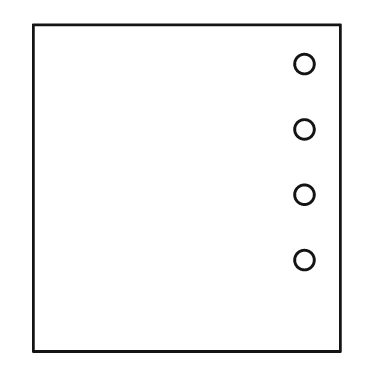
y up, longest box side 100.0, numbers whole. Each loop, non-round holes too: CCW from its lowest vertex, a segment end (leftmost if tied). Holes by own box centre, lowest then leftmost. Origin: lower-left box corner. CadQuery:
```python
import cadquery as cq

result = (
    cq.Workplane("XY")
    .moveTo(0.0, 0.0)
    .lineTo(94.0, 0.0)
    .lineTo(94.0, 100.0)
    .lineTo(0.0, 100.0)
    .close()
    .moveTo(83.0, 28.0)
    .circle(3.0)
    .moveTo(83.0, 48.0)
    .circle(3.0)
    .moveTo(83.0, 68.0)
    .circle(3.0)
    .moveTo(83.0, 88.0)
    .circle(3.0)
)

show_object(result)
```